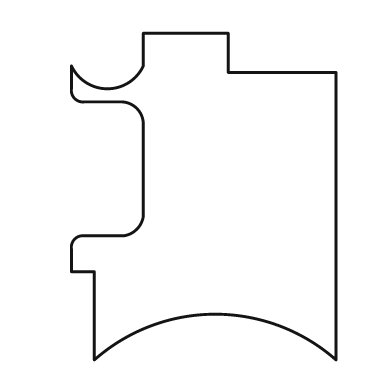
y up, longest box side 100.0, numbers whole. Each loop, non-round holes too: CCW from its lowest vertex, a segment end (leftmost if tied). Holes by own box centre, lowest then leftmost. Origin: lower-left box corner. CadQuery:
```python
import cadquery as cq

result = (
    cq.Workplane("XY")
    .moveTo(7.0, 0.0)
    .threePointArc((44.0, 14.0), (81.0, 0.0))
    .lineTo(81.0, 88.0)
    .lineTo(48.0, 88.0)
    .lineTo(48.0, 100.0)
    .lineTo(22.0, 100.0)
    .lineTo(22.0, 90.0)
    .threePointArc((11.0, 83.0), (0.0, 90.0))
    .lineTo(0.0, 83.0)
    .threePointArc((1.0, 80.0), (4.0, 79.0))
    .lineTo(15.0, 79.0)
    .threePointArc((20.0, 77.0), (22.0, 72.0))
    .lineTo(22.0, 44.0)
    .threePointArc((20.0, 40.0), (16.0, 38.0))
    .lineTo(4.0, 38.0)
    .threePointArc((1.0, 37.0), (0.0, 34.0))
    .lineTo(0.0, 27.0)
    .lineTo(7.0, 27.0)
    .close()
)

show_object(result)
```